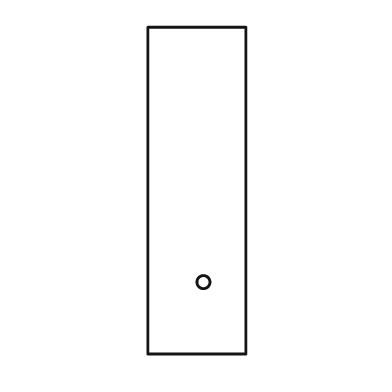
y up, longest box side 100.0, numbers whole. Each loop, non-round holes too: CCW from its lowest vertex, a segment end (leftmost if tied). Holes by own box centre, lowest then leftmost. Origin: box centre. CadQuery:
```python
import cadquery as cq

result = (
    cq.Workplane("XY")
    .moveTo(-15.0, -50.0)
    .lineTo(15.0, -50.0)
    .lineTo(15.0, 50.0)
    .lineTo(-15.0, 50.0)
    .close()
    .moveTo(2.0, -28.0)
    .circle(2.0)
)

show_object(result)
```